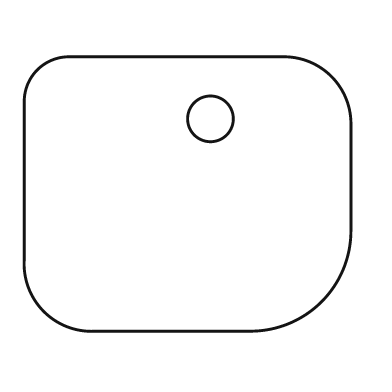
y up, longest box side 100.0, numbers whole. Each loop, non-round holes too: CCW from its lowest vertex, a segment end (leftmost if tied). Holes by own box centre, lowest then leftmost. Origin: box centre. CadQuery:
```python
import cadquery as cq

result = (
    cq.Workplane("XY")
    .moveTo(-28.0, -42.0)
    .lineTo(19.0, -42.0)
    .threePointArc((41.0, -33.0), (50.0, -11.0))
    .lineTo(50.0, 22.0)
    .threePointArc((44.0, 36.0), (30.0, 42.0))
    .lineTo(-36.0, 42.0)
    .threePointArc((-46.0, 38.0), (-50.0, 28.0))
    .lineTo(-50.0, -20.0)
    .threePointArc((-44.0, -36.0), (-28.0, -42.0))
    .close()
    .moveTo(7.0, 23.0)
    .circle(7.0)
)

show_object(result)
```